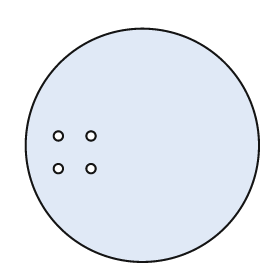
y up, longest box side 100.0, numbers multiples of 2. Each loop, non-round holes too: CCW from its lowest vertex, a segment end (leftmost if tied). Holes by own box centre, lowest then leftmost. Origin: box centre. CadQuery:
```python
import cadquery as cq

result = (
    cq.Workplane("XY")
    .moveTo(0.0, 0.0)
    .circle(50.0)
    .moveTo(-36.0, -10.0)
    .circle(2.0)
    .moveTo(-22.0, -10.0)
    .circle(2.0)
    .moveTo(-36.0, 4.0)
    .circle(2.0)
    .moveTo(-22.0, 4.0)
    .circle(2.0)
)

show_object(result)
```